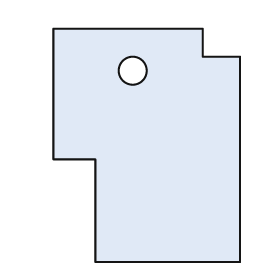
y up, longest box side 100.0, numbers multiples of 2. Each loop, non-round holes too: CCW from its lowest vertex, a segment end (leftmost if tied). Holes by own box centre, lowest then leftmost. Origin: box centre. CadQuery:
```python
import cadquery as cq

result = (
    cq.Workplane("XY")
    .moveTo(-22.0, -50.0)
    .lineTo(40.0, -50.0)
    .lineTo(40.0, 38.0)
    .lineTo(24.0, 38.0)
    .lineTo(24.0, 50.0)
    .lineTo(-40.0, 50.0)
    .lineTo(-40.0, -6.0)
    .lineTo(-22.0, -6.0)
    .close()
    .moveTo(-6.0, 32.0)
    .circle(6.0)
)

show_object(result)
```